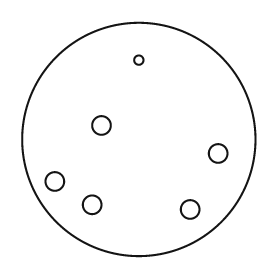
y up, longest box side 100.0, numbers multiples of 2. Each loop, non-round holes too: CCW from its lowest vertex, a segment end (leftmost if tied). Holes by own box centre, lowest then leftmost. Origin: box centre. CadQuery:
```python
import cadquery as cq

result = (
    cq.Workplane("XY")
    .moveTo(0.0, 0.0)
    .circle(50.0)
    .moveTo(22.0, -30.0)
    .circle(4.0)
    .moveTo(-20.0, -28.0)
    .circle(4.0)
    .moveTo(-36.0, -18.0)
    .circle(4.0)
    .moveTo(34.0, -6.0)
    .circle(4.0)
    .moveTo(-16.0, 6.0)
    .circle(4.0)
    .moveTo(0.0, 34.0)
    .circle(2.0)
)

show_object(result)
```